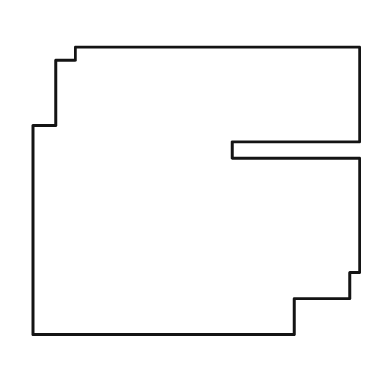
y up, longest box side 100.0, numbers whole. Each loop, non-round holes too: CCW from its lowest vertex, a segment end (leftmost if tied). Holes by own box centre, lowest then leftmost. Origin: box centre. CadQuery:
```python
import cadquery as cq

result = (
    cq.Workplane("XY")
    .moveTo(-50.0, -44.0)
    .lineTo(30.0, -44.0)
    .lineTo(30.0, -33.0)
    .lineTo(47.0, -33.0)
    .lineTo(47.0, -25.0)
    .lineTo(50.0, -25.0)
    .lineTo(50.0, 10.0)
    .lineTo(11.0, 10.0)
    .lineTo(11.0, 15.0)
    .lineTo(50.0, 15.0)
    .lineTo(50.0, 44.0)
    .lineTo(-37.0, 44.0)
    .lineTo(-37.0, 40.0)
    .lineTo(-43.0, 40.0)
    .lineTo(-43.0, 20.0)
    .lineTo(-50.0, 20.0)
    .close()
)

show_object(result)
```